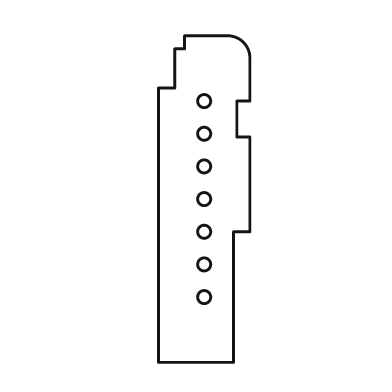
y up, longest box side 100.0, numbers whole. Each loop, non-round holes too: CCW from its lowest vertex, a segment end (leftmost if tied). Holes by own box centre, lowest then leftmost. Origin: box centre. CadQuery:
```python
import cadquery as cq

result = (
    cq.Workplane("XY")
    .moveTo(-14.0, -50.0)
    .lineTo(9.0, -50.0)
    .lineTo(9.0, -10.0)
    .lineTo(14.0, -10.0)
    .lineTo(14.0, 19.0)
    .lineTo(10.0, 19.0)
    .lineTo(10.0, 30.0)
    .lineTo(14.0, 30.0)
    .lineTo(14.0, 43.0)
    .threePointArc((12.0, 48.0), (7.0, 50.0))
    .lineTo(-6.0, 50.0)
    .lineTo(-6.0, 46.0)
    .lineTo(-9.0, 46.0)
    .lineTo(-9.0, 34.0)
    .lineTo(-14.0, 34.0)
    .close()
    .moveTo(0.0, -30.0)
    .circle(2.0)
    .moveTo(0.0, -20.0)
    .circle(2.0)
    .moveTo(0.0, -10.0)
    .circle(2.0)
    .moveTo(0.0, 0.0)
    .circle(2.0)
    .moveTo(0.0, 10.0)
    .circle(2.0)
    .moveTo(0.0, 20.0)
    .circle(2.0)
    .moveTo(0.0, 30.0)
    .circle(2.0)
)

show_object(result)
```